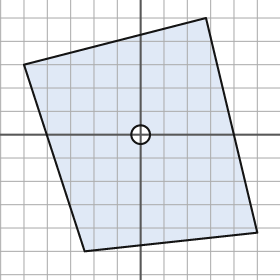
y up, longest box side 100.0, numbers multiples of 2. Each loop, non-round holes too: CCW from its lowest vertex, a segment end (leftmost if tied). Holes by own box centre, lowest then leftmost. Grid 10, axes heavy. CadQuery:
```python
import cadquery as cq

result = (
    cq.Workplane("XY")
    .moveTo(-24.0, -50.0)
    .lineTo(50.0, -42.0)
    .lineTo(28.0, 50.0)
    .lineTo(-50.0, 30.0)
    .close()
    .moveTo(0.0, 0.0)
    .circle(4.0)
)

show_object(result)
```